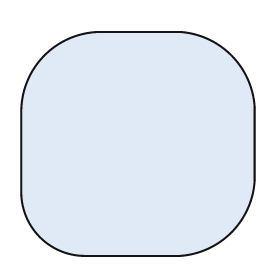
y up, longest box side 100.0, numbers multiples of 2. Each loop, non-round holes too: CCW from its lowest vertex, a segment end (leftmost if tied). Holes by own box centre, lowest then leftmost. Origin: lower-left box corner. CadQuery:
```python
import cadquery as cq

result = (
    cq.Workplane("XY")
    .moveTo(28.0, 0.0)
    .lineTo(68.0, 0.0)
    .threePointArc((90.0, 10.0), (100.0, 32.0))
    .lineTo(100.0, 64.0)
    .threePointArc((90.0, 86.0), (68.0, 96.0))
    .lineTo(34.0, 96.0)
    .threePointArc((10.0, 86.0), (0.0, 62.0))
    .lineTo(0.0, 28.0)
    .threePointArc((8.0, 8.0), (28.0, 0.0))
    .close()
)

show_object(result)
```